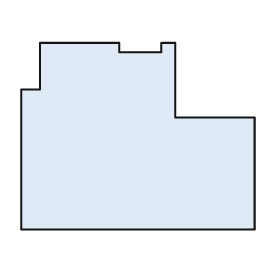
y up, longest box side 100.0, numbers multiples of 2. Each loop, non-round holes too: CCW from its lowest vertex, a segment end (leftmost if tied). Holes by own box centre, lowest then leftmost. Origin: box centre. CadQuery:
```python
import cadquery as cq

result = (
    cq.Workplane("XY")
    .moveTo(-50.0, -40.0)
    .lineTo(50.0, -40.0)
    .lineTo(50.0, 8.0)
    .lineTo(16.0, 8.0)
    .lineTo(16.0, 40.0)
    .lineTo(10.0, 40.0)
    .lineTo(10.0, 36.0)
    .lineTo(-8.0, 36.0)
    .lineTo(-8.0, 40.0)
    .lineTo(-42.0, 40.0)
    .lineTo(-42.0, 20.0)
    .lineTo(-50.0, 20.0)
    .close()
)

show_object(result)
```